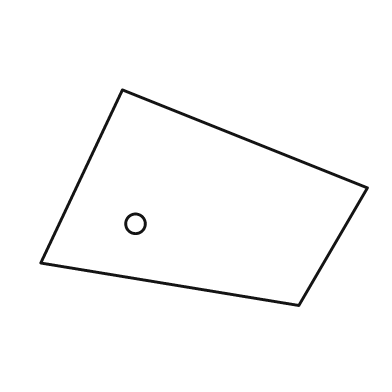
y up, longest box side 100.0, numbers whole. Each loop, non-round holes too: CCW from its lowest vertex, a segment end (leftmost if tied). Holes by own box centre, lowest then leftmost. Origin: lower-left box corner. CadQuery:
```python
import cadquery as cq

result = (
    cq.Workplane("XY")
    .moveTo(79.0, 0.0)
    .lineTo(100.0, 36.0)
    .lineTo(25.0, 66.0)
    .lineTo(0.0, 13.0)
    .close()
    .moveTo(29.0, 25.0)
    .circle(3.0)
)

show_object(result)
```